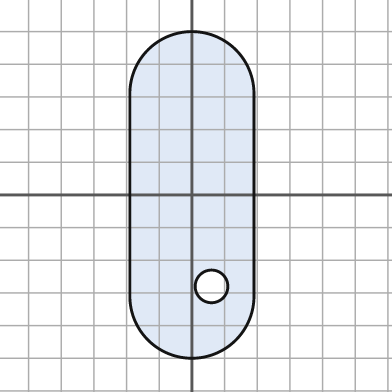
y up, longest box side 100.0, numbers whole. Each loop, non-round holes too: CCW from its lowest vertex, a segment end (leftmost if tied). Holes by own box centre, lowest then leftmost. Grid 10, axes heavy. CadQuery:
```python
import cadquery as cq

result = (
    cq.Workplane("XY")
    .moveTo(-19.0, -31.0)
    .threePointArc((0.0, -50.0), (19.0, -31.0))
    .lineTo(19.0, 31.0)
    .threePointArc((0.0, 50.0), (-19.0, 31.0))
    .close()
    .moveTo(6.0, -28.0)
    .circle(5.0)
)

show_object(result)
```